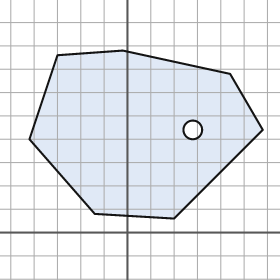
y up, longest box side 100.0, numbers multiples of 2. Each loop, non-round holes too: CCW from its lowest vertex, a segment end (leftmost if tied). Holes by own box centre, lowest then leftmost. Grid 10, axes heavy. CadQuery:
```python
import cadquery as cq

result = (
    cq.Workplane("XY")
    .moveTo(20.0, 6.0)
    .lineTo(58.0, 44.0)
    .lineTo(44.0, 68.0)
    .lineTo(-2.0, 78.0)
    .lineTo(-30.0, 76.0)
    .lineTo(-42.0, 40.0)
    .lineTo(-14.0, 8.0)
    .close()
    .moveTo(28.0, 44.0)
    .circle(4.0)
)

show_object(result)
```